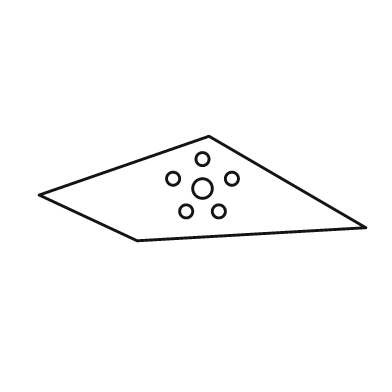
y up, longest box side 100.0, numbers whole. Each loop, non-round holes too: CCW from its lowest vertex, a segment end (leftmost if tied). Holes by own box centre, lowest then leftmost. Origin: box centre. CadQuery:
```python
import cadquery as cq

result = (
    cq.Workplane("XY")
    .moveTo(-20.0, -16.0)
    .lineTo(50.0, -12.0)
    .lineTo(2.0, 16.0)
    .lineTo(-50.0, -2.0)
    .close()
    .moveTo(-5.0, -7.0)
    .circle(2.0)
    .moveTo(5.0, -7.0)
    .circle(2.0)
    .moveTo(0.0, 0.0)
    .circle(3.0)
    .moveTo(-9.0, 3.0)
    .circle(2.0)
    .moveTo(9.0, 3.0)
    .circle(2.0)
    .moveTo(0.0, 9.0)
    .circle(2.0)
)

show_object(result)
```